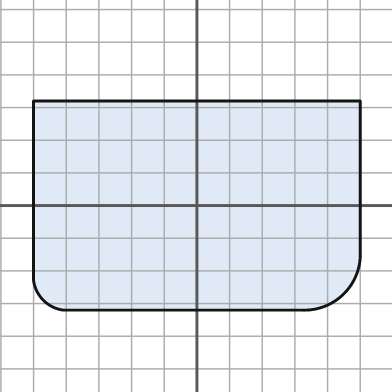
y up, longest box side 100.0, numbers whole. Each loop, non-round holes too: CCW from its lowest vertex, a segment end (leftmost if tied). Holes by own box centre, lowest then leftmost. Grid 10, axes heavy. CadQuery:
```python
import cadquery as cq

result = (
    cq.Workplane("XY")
    .moveTo(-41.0, -32.0)
    .lineTo(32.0, -32.0)
    .threePointArc((45.0, -27.0), (50.0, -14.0))
    .lineTo(50.0, 32.0)
    .lineTo(-50.0, 32.0)
    .lineTo(-50.0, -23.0)
    .threePointArc((-47.0, -29.0), (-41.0, -32.0))
    .close()
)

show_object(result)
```